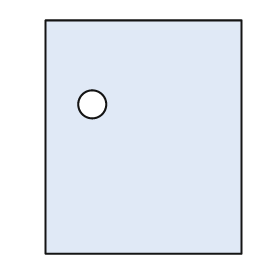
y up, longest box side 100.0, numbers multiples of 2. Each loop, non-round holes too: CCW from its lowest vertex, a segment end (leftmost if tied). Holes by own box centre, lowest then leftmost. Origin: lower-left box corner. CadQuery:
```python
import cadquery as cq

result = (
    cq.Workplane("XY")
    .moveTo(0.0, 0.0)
    .lineTo(84.0, 0.0)
    .lineTo(84.0, 100.0)
    .lineTo(0.0, 100.0)
    .close()
    .moveTo(20.0, 64.0)
    .circle(6.0)
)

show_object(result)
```